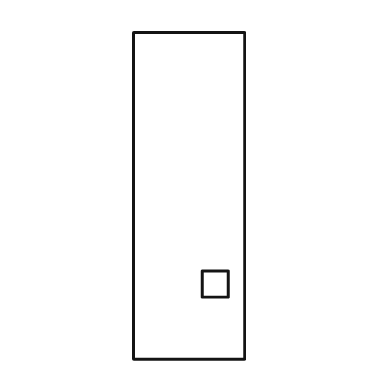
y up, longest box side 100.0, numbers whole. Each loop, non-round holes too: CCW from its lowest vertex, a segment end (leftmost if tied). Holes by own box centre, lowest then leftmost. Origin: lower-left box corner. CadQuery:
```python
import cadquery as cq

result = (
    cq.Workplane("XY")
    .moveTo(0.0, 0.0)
    .lineTo(34.0, 0.0)
    .lineTo(34.0, 100.0)
    .lineTo(0.0, 100.0)
    .close()
    .moveTo(21.0, 19.0)
    .lineTo(29.0, 19.0)
    .lineTo(29.0, 27.0)
    .lineTo(21.0, 27.0)
    .close()
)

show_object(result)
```